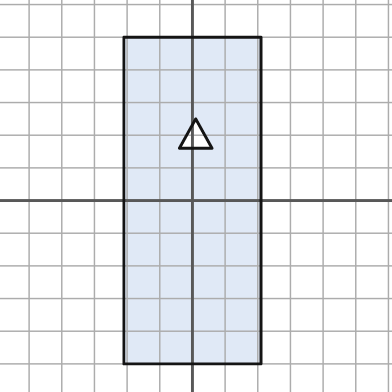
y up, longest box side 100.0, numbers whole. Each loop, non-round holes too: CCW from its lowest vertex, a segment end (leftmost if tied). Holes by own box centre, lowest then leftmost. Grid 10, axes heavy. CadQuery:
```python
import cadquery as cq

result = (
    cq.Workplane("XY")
    .moveTo(-21.0, -50.0)
    .lineTo(21.0, -50.0)
    .lineTo(21.0, 50.0)
    .lineTo(-21.0, 50.0)
    .close()
    .moveTo(-4.0, 16.0)
    .lineTo(6.0, 16.0)
    .lineTo(1.0, 25.0)
    .close()
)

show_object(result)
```